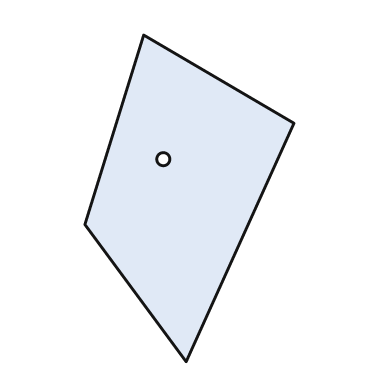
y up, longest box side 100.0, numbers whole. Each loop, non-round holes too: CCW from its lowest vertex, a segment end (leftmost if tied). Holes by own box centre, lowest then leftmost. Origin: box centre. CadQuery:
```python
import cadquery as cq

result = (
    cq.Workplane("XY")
    .moveTo(-1.0, -50.0)
    .lineTo(32.0, 23.0)
    .lineTo(-14.0, 50.0)
    .lineTo(-32.0, -8.0)
    .close()
    .moveTo(-8.0, 12.0)
    .circle(2.0)
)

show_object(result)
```